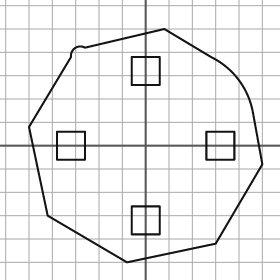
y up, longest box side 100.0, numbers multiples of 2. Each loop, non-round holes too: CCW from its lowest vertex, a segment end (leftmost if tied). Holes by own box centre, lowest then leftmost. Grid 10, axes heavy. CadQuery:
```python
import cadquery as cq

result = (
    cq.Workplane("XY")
    .moveTo(-8.0, -50.0)
    .lineTo(30.0, -42.0)
    .lineTo(50.0, -8.0)
    .lineTo(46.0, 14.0)
    .threePointArc((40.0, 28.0), (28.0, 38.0))
    .lineTo(8.0, 50.0)
    .lineTo(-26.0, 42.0)
    .threePointArc((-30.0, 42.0), (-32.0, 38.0))
    .lineTo(-50.0, 8.0)
    .lineTo(-42.0, -30.0)
    .close()
    .moveTo(-6.0, -38.0)
    .lineTo(6.0, -38.0)
    .lineTo(6.0, -26.0)
    .lineTo(-6.0, -26.0)
    .close()
    .moveTo(-38.0, -6.0)
    .lineTo(-26.0, -6.0)
    .lineTo(-26.0, 6.0)
    .lineTo(-38.0, 6.0)
    .close()
    .moveTo(26.0, -6.0)
    .lineTo(38.0, -6.0)
    .lineTo(38.0, 6.0)
    .lineTo(26.0, 6.0)
    .close()
    .moveTo(-6.0, 26.0)
    .lineTo(6.0, 26.0)
    .lineTo(6.0, 38.0)
    .lineTo(-6.0, 38.0)
    .close()
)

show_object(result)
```